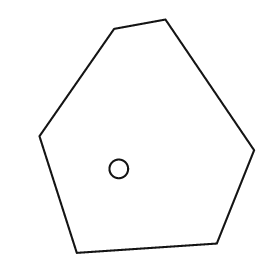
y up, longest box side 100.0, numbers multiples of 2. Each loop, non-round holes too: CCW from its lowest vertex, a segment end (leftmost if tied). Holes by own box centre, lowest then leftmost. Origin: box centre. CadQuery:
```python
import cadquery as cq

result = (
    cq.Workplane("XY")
    .moveTo(-30.0, -50.0)
    .lineTo(30.0, -46.0)
    .lineTo(46.0, -6.0)
    .lineTo(8.0, 50.0)
    .lineTo(-14.0, 46.0)
    .lineTo(-46.0, 0.0)
    .close()
    .moveTo(-12.0, -14.0)
    .circle(4.0)
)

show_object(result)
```